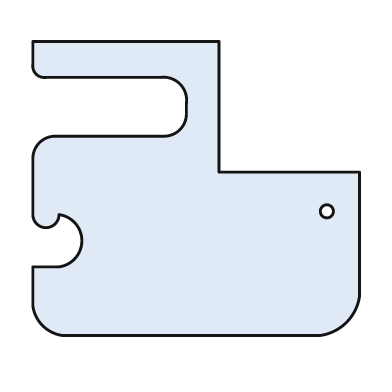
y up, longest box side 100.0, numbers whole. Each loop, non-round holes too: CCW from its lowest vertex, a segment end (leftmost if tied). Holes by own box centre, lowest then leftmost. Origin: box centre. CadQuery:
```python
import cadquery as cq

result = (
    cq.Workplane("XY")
    .moveTo(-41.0, -45.0)
    .lineTo(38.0, -45.0)
    .threePointArc((46.0, -41.0), (50.0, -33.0))
    .lineTo(50.0, 5.0)
    .lineTo(7.0, 5.0)
    .lineTo(7.0, 45.0)
    .lineTo(-50.0, 45.0)
    .lineTo(-50.0, 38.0)
    .threePointArc((-49.0, 35.0), (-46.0, 34.0))
    .lineTo(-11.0, 34.0)
    .threePointArc((-5.0, 32.0), (-3.0, 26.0))
    .lineTo(-3.0, 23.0)
    .threePointArc((-5.0, 18.0), (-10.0, 16.0))
    .lineTo(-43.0, 16.0)
    .threePointArc((-48.0, 14.0), (-50.0, 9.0))
    .lineTo(-50.0, -8.0)
    .threePointArc((-46.0, -12.0), (-42.0, -8.0))
    .threePointArc((-35.0, -16.0), (-42.0, -24.0))
    .lineTo(-50.0, -24.0)
    .lineTo(-50.0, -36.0)
    .threePointArc((-47.0, -42.0), (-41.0, -45.0))
    .close()
    .moveTo(40.0, -7.0)
    .circle(2.0)
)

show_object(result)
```